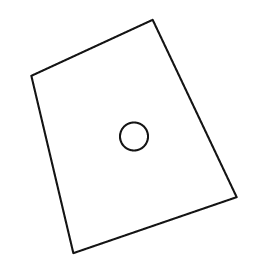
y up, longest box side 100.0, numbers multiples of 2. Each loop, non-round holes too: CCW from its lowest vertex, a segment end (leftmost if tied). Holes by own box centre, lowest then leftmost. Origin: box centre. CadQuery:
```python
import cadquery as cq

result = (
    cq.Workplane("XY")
    .moveTo(-26.0, -50.0)
    .lineTo(44.0, -26.0)
    .lineTo(8.0, 50.0)
    .lineTo(-44.0, 26.0)
    .close()
    .moveTo(0.0, 0.0)
    .circle(6.0)
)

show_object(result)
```